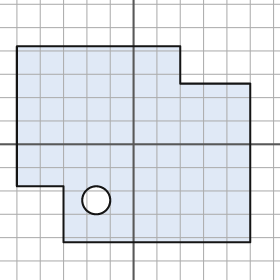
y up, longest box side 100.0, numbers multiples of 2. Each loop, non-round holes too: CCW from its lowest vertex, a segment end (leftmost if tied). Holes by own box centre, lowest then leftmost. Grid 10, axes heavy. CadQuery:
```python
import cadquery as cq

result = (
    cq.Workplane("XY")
    .moveTo(-30.0, -42.0)
    .lineTo(50.0, -42.0)
    .lineTo(50.0, 26.0)
    .lineTo(20.0, 26.0)
    .lineTo(20.0, 42.0)
    .lineTo(-50.0, 42.0)
    .lineTo(-50.0, -18.0)
    .lineTo(-30.0, -18.0)
    .close()
    .moveTo(-16.0, -24.0)
    .circle(6.0)
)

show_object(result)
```